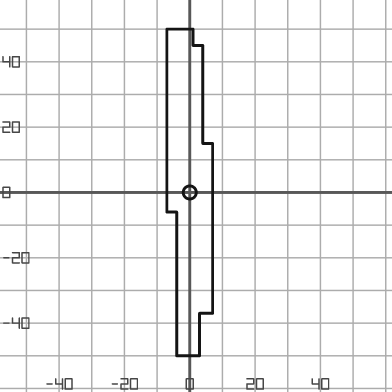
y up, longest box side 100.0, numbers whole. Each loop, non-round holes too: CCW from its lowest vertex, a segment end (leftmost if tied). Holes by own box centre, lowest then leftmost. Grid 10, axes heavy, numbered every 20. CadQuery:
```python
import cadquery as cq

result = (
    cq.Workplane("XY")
    .moveTo(-4.0, -50.0)
    .lineTo(3.0, -50.0)
    .lineTo(3.0, -37.0)
    .lineTo(7.0, -37.0)
    .lineTo(7.0, 15.0)
    .lineTo(4.0, 15.0)
    .lineTo(4.0, 45.0)
    .lineTo(1.0, 45.0)
    .lineTo(1.0, 50.0)
    .lineTo(-7.0, 50.0)
    .lineTo(-7.0, -6.0)
    .lineTo(-4.0, -6.0)
    .close()
    .moveTo(0.0, 0.0)
    .circle(2.0)
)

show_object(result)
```